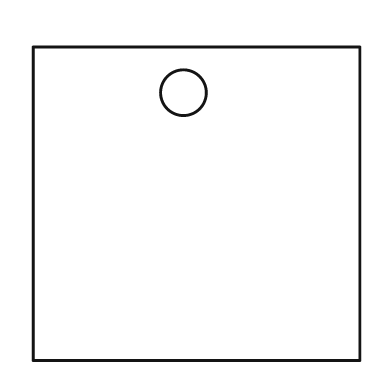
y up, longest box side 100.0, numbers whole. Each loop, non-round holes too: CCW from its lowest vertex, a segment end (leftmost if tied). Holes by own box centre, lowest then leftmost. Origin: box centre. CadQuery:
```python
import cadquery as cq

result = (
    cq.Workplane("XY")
    .moveTo(-50.0, -48.0)
    .lineTo(50.0, -48.0)
    .lineTo(50.0, 48.0)
    .lineTo(-50.0, 48.0)
    .close()
    .moveTo(-4.0, 34.0)
    .circle(7.0)
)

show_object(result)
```